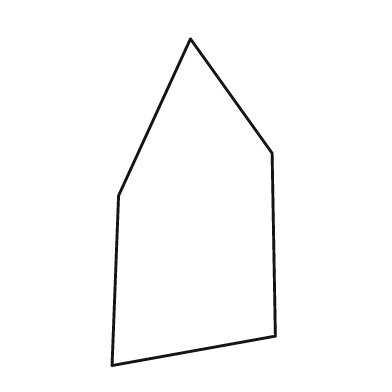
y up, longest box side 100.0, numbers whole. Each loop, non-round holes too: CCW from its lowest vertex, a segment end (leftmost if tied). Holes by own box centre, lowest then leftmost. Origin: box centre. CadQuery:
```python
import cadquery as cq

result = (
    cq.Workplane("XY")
    .moveTo(-25.0, -50.0)
    .lineTo(25.0, -41.0)
    .lineTo(24.0, 15.0)
    .lineTo(-1.0, 50.0)
    .lineTo(-23.0, 2.0)
    .close()
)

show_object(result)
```